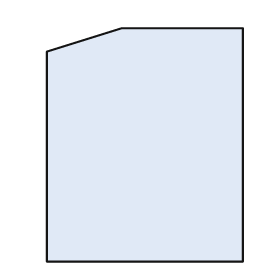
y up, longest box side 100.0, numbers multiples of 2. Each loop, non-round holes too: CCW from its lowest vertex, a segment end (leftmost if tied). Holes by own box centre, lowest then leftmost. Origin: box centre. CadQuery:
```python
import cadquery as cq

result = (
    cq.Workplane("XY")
    .moveTo(-42.0, -50.0)
    .lineTo(42.0, -50.0)
    .lineTo(42.0, 50.0)
    .lineTo(-10.0, 50.0)
    .lineTo(-42.0, 40.0)
    .close()
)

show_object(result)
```